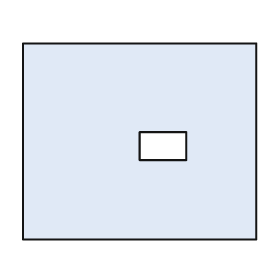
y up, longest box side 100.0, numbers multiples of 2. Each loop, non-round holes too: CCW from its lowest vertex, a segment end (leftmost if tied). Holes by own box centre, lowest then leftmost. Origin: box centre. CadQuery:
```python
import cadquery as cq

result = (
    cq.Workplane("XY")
    .moveTo(-50.0, -42.0)
    .lineTo(50.0, -42.0)
    .lineTo(50.0, 42.0)
    .lineTo(-50.0, 42.0)
    .close()
    .moveTo(0.0, -8.0)
    .lineTo(20.0, -8.0)
    .lineTo(20.0, 4.0)
    .lineTo(0.0, 4.0)
    .close()
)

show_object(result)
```